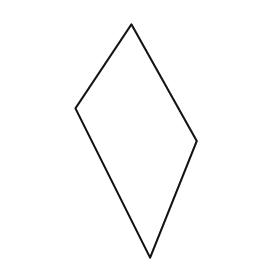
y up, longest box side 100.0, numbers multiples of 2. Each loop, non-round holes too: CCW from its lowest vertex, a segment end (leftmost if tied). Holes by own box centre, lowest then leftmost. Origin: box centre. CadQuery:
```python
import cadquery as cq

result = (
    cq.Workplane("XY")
    .moveTo(6.0, -50.0)
    .lineTo(26.0, 0.0)
    .lineTo(-2.0, 50.0)
    .lineTo(-26.0, 14.0)
    .close()
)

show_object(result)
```